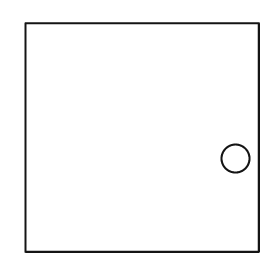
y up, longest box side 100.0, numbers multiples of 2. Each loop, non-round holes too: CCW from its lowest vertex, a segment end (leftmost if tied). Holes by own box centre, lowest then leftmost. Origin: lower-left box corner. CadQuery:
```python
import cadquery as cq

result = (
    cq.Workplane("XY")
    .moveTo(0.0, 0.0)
    .lineTo(100.0, 0.0)
    .lineTo(100.0, 98.0)
    .lineTo(0.0, 98.0)
    .close()
    .moveTo(90.0, 40.0)
    .circle(6.0)
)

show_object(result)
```